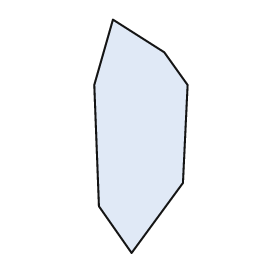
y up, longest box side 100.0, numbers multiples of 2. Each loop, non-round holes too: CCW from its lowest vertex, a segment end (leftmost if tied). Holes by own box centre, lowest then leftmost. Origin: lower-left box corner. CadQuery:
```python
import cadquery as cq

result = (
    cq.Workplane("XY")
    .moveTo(16.0, 0.0)
    .lineTo(38.0, 30.0)
    .lineTo(40.0, 72.0)
    .lineTo(30.0, 86.0)
    .lineTo(8.0, 100.0)
    .lineTo(0.0, 72.0)
    .lineTo(2.0, 20.0)
    .close()
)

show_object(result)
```